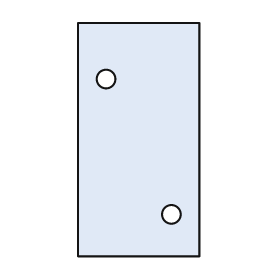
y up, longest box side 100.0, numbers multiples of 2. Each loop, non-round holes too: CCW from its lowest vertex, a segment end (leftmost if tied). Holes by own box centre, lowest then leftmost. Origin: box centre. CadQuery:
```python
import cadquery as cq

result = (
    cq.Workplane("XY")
    .moveTo(-26.0, -50.0)
    .lineTo(26.0, -50.0)
    .lineTo(26.0, 50.0)
    .lineTo(-26.0, 50.0)
    .close()
    .moveTo(14.0, -32.0)
    .circle(4.0)
    .moveTo(-14.0, 26.0)
    .circle(4.0)
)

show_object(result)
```